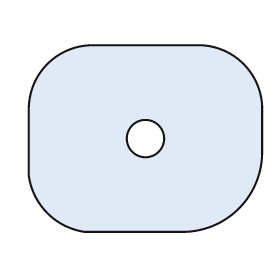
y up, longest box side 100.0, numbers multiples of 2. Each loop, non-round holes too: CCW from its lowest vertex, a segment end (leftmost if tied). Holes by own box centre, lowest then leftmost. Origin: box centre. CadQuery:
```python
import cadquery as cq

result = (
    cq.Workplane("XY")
    .moveTo(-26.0, -40.0)
    .lineTo(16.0, -40.0)
    .threePointArc((40.0, -30.0), (50.0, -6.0))
    .lineTo(50.0, 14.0)
    .threePointArc((42.0, 32.0), (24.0, 40.0))
    .lineTo(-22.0, 40.0)
    .threePointArc((-42.0, 32.0), (-50.0, 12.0))
    .lineTo(-50.0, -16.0)
    .threePointArc((-42.0, -32.0), (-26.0, -40.0))
    .close()
    .moveTo(0.0, 0.0)
    .circle(8.0)
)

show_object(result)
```